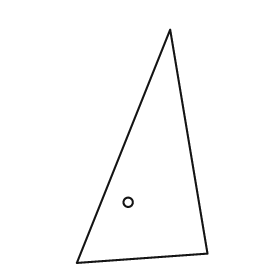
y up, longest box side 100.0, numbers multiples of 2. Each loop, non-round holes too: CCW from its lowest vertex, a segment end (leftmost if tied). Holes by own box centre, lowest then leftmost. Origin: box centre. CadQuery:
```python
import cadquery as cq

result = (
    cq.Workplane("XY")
    .moveTo(-28.0, -50.0)
    .lineTo(28.0, -46.0)
    .lineTo(12.0, 50.0)
    .close()
    .moveTo(-6.0, -24.0)
    .circle(2.0)
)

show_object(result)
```